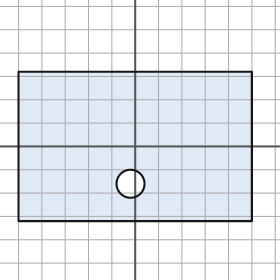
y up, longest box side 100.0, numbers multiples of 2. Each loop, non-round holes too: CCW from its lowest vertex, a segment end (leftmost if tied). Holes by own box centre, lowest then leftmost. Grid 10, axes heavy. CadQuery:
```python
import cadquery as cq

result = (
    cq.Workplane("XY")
    .moveTo(-50.0, -32.0)
    .lineTo(50.0, -32.0)
    .lineTo(50.0, 32.0)
    .lineTo(-50.0, 32.0)
    .close()
    .moveTo(-2.0, -16.0)
    .circle(6.0)
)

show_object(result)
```